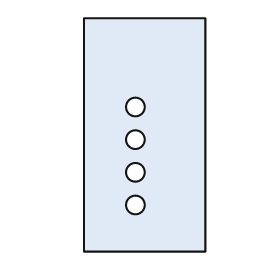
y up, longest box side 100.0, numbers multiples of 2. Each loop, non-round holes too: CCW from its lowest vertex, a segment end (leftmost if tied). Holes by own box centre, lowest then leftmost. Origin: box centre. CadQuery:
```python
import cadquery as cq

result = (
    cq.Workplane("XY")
    .moveTo(-26.0, -50.0)
    .lineTo(26.0, -50.0)
    .lineTo(26.0, 50.0)
    .lineTo(-26.0, 50.0)
    .close()
    .moveTo(-4.0, -30.0)
    .circle(4.0)
    .moveTo(-4.0, -16.0)
    .circle(4.0)
    .moveTo(-4.0, -2.0)
    .circle(4.0)
    .moveTo(-4.0, 12.0)
    .circle(4.0)
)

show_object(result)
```